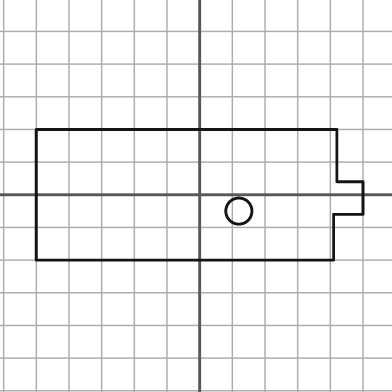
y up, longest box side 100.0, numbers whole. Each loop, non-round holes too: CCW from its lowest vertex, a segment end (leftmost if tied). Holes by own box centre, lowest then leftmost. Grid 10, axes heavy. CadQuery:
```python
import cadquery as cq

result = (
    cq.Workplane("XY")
    .moveTo(-50.0, -20.0)
    .lineTo(41.0, -20.0)
    .lineTo(41.0, -6.0)
    .lineTo(50.0, -6.0)
    .lineTo(50.0, 4.0)
    .lineTo(42.0, 4.0)
    .lineTo(42.0, 20.0)
    .lineTo(-50.0, 20.0)
    .close()
    .moveTo(12.0, -5.0)
    .circle(4.0)
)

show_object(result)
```